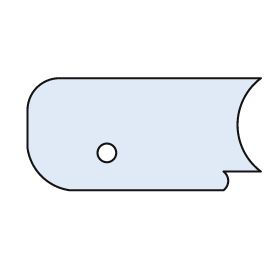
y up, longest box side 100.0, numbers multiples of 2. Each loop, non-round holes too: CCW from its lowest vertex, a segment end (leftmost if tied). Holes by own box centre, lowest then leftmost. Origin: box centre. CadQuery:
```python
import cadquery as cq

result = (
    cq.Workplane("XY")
    .moveTo(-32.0, -24.0)
    .lineTo(34.0, -24.0)
    .threePointArc((36.0, -20.0), (34.0, -16.0))
    .lineTo(50.0, -16.0)
    .threePointArc((40.0, 4.0), (50.0, 24.0))
    .lineTo(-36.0, 24.0)
    .threePointArc((-46.0, 20.0), (-50.0, 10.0))
    .lineTo(-50.0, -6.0)
    .threePointArc((-44.0, -18.0), (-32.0, -24.0))
    .close()
    .moveTo(-16.0, -8.0)
    .circle(4.0)
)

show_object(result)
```